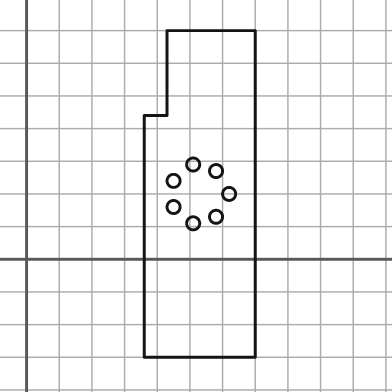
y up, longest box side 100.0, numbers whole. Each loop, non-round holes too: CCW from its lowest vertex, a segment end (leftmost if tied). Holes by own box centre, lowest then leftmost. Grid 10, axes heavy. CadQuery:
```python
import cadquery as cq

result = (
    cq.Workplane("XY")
    .moveTo(36.0, -30.0)
    .lineTo(70.0, -30.0)
    .lineTo(70.0, 70.0)
    .lineTo(43.0, 70.0)
    .lineTo(43.0, 44.0)
    .lineTo(36.0, 44.0)
    .close()
    .moveTo(51.0, 11.0)
    .circle(2.0)
    .moveTo(58.0, 13.0)
    .circle(2.0)
    .moveTo(45.0, 16.0)
    .circle(2.0)
    .moveTo(62.0, 20.0)
    .circle(2.0)
    .moveTo(45.0, 24.0)
    .circle(2.0)
    .moveTo(58.0, 27.0)
    .circle(2.0)
    .moveTo(51.0, 29.0)
    .circle(2.0)
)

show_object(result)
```